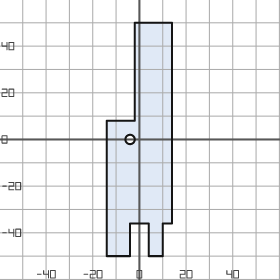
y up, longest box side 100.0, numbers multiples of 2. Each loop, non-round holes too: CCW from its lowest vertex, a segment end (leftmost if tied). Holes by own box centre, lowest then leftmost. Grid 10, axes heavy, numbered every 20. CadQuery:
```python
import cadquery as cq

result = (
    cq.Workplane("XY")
    .moveTo(-14.0, -50.0)
    .lineTo(-4.0, -50.0)
    .lineTo(-4.0, -36.0)
    .lineTo(4.0, -36.0)
    .lineTo(4.0, -50.0)
    .lineTo(10.0, -50.0)
    .lineTo(10.0, -36.0)
    .lineTo(14.0, -36.0)
    .lineTo(14.0, 50.0)
    .lineTo(-2.0, 50.0)
    .lineTo(-2.0, 8.0)
    .lineTo(-14.0, 8.0)
    .close()
    .moveTo(-4.0, 0.0)
    .circle(2.0)
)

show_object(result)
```